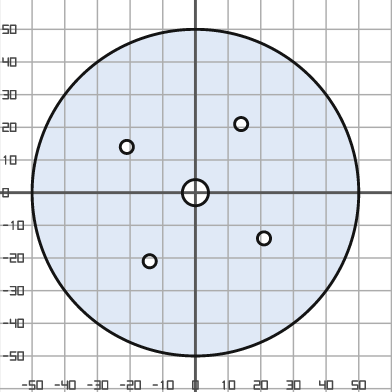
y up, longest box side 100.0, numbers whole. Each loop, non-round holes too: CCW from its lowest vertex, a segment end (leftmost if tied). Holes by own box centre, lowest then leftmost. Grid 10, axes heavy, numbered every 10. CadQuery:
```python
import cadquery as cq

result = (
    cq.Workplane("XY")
    .moveTo(0.0, 0.0)
    .circle(50.0)
    .moveTo(-14.0, -21.0)
    .circle(2.0)
    .moveTo(21.0, -14.0)
    .circle(2.0)
    .moveTo(0.0, 0.0)
    .circle(4.0)
    .moveTo(-21.0, 14.0)
    .circle(2.0)
    .moveTo(14.0, 21.0)
    .circle(2.0)
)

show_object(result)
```